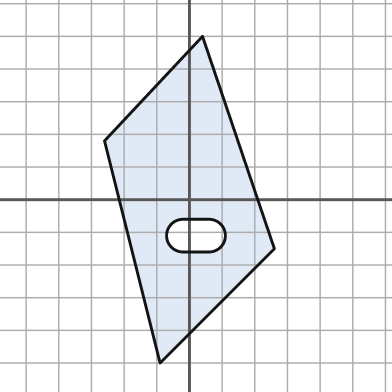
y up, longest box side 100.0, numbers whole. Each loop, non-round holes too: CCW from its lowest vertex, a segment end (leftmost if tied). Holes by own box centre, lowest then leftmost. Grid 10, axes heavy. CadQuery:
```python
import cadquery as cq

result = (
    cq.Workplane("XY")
    .moveTo(-9.0, -50.0)
    .lineTo(26.0, -15.0)
    .lineTo(4.0, 50.0)
    .lineTo(-26.0, 18.0)
    .close()
    .moveTo(-2.0, -16.0)
    .lineTo(6.0, -16.0)
    .threePointArc((11.0, -11.0), (6.0, -6.0))
    .lineTo(-2.0, -6.0)
    .threePointArc((-7.0, -11.0), (-2.0, -16.0))
    .close()
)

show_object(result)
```